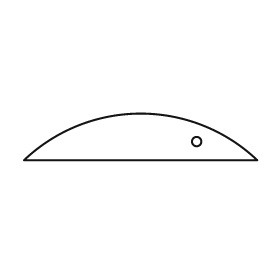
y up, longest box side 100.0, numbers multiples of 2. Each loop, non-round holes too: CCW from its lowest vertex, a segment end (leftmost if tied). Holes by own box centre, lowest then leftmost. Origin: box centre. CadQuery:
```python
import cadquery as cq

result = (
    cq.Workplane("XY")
    .moveTo(-50.0, -10.0)
    .lineTo(50.0, -10.0)
    .threePointArc((0.0, 10.0), (-50.0, -10.0))
    .close()
    .moveTo(24.0, -2.0)
    .circle(2.0)
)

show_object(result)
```